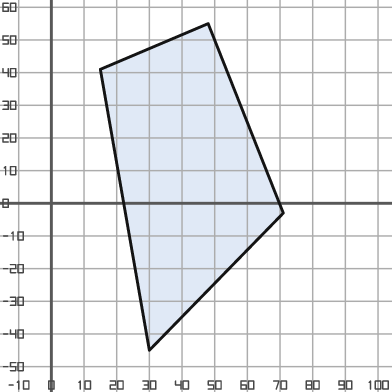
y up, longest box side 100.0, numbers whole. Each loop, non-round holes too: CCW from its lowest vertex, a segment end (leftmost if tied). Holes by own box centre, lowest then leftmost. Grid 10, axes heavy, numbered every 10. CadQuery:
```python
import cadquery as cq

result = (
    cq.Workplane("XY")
    .moveTo(30.0, -45.0)
    .lineTo(71.0, -3.0)
    .lineTo(48.0, 55.0)
    .lineTo(15.0, 41.0)
    .close()
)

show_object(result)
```